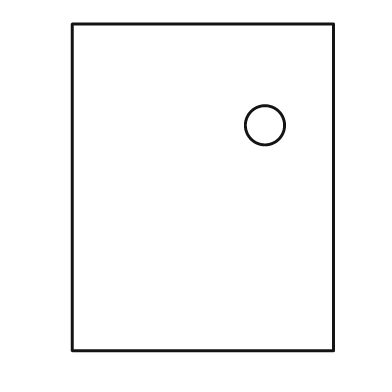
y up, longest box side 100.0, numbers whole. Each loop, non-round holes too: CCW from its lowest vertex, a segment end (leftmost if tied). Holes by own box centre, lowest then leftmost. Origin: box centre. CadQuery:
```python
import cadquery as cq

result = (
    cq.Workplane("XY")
    .moveTo(-40.0, -50.0)
    .lineTo(40.0, -50.0)
    .lineTo(40.0, 50.0)
    .lineTo(-40.0, 50.0)
    .close()
    .moveTo(19.0, 19.0)
    .circle(6.0)
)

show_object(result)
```